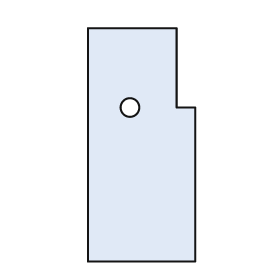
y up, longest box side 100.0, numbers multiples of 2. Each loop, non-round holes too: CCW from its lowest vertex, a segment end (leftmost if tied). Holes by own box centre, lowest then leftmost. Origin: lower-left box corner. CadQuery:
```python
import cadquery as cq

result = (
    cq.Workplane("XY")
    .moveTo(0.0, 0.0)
    .lineTo(46.0, 0.0)
    .lineTo(46.0, 66.0)
    .lineTo(38.0, 66.0)
    .lineTo(38.0, 100.0)
    .lineTo(0.0, 100.0)
    .close()
    .moveTo(18.0, 66.0)
    .circle(4.0)
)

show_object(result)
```